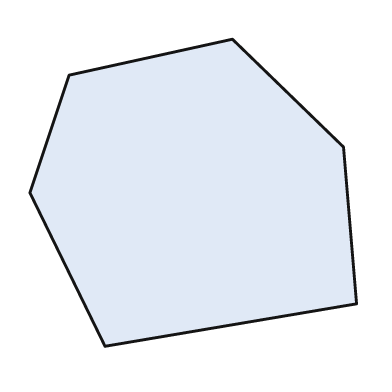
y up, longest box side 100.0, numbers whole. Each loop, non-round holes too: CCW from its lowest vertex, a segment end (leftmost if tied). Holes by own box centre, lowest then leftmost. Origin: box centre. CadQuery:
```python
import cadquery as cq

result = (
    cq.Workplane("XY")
    .moveTo(-27.0, -47.0)
    .lineTo(50.0, -34.0)
    .lineTo(46.0, 14.0)
    .lineTo(12.0, 47.0)
    .lineTo(-38.0, 36.0)
    .lineTo(-50.0, 0.0)
    .close()
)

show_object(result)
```